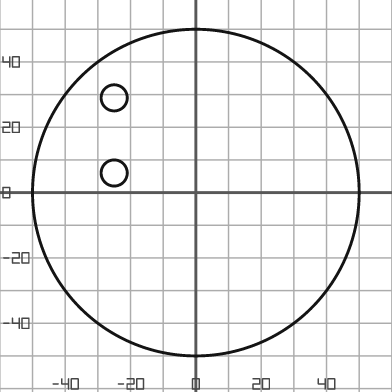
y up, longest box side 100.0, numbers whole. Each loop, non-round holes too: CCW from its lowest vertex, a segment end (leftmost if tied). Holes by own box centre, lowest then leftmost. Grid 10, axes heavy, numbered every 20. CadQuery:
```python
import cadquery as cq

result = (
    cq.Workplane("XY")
    .moveTo(0.0, 0.0)
    .circle(50.0)
    .moveTo(-25.0, 6.0)
    .circle(4.0)
    .moveTo(-25.0, 29.0)
    .circle(4.0)
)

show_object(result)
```